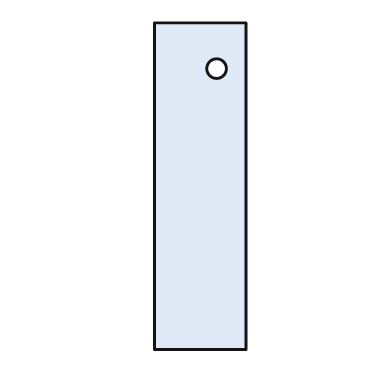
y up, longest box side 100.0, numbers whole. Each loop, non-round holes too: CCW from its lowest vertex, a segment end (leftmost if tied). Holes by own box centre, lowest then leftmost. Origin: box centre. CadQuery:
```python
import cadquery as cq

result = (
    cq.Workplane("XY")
    .moveTo(-14.0, -50.0)
    .lineTo(14.0, -50.0)
    .lineTo(14.0, 50.0)
    .lineTo(-14.0, 50.0)
    .close()
    .moveTo(5.0, 36.0)
    .circle(3.0)
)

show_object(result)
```